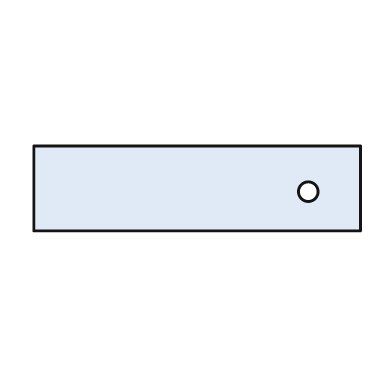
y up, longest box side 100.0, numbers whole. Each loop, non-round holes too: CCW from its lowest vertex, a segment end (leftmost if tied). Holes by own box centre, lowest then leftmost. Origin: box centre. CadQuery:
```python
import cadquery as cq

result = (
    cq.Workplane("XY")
    .moveTo(-50.0, -13.0)
    .lineTo(50.0, -13.0)
    .lineTo(50.0, 13.0)
    .lineTo(-50.0, 13.0)
    .close()
    .moveTo(34.0, -1.0)
    .circle(3.0)
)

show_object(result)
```